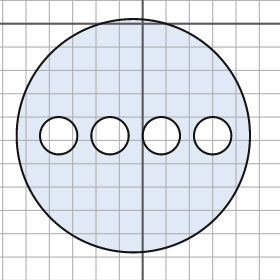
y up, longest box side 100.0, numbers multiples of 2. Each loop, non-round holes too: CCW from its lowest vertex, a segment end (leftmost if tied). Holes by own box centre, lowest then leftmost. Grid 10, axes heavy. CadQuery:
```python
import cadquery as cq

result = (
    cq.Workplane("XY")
    .moveTo(-4.0, -48.0)
    .circle(50.0)
    .moveTo(-36.0, -48.0)
    .circle(8.0)
    .moveTo(-14.0, -48.0)
    .circle(8.0)
    .moveTo(8.0, -48.0)
    .circle(8.0)
    .moveTo(30.0, -48.0)
    .circle(8.0)
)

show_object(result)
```